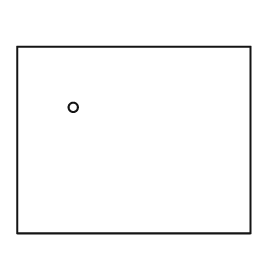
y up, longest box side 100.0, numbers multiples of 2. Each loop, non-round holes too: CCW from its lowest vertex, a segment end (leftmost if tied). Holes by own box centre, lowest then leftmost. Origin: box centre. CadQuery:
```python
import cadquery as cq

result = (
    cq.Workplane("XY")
    .moveTo(-50.0, -40.0)
    .lineTo(50.0, -40.0)
    .lineTo(50.0, 40.0)
    .lineTo(-50.0, 40.0)
    .close()
    .moveTo(-26.0, 14.0)
    .circle(2.0)
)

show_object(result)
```